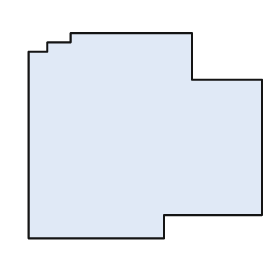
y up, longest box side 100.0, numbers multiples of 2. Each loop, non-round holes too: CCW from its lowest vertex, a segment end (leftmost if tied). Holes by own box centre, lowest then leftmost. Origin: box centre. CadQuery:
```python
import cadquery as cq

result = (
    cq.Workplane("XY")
    .moveTo(-50.0, -44.0)
    .lineTo(8.0, -44.0)
    .lineTo(8.0, -34.0)
    .lineTo(50.0, -34.0)
    .lineTo(50.0, 24.0)
    .lineTo(20.0, 24.0)
    .lineTo(20.0, 44.0)
    .lineTo(-32.0, 44.0)
    .lineTo(-32.0, 40.0)
    .lineTo(-42.0, 40.0)
    .lineTo(-42.0, 36.0)
    .lineTo(-50.0, 36.0)
    .close()
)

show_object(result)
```